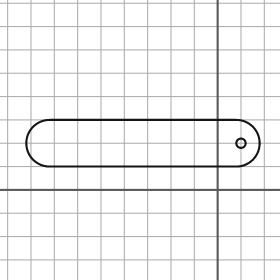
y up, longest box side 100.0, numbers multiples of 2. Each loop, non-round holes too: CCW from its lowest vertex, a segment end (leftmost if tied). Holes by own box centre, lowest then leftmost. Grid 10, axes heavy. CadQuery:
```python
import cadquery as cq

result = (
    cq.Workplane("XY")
    .moveTo(-72.0, 10.0)
    .lineTo(8.0, 10.0)
    .threePointArc((18.0, 20.0), (8.0, 30.0))
    .lineTo(-72.0, 30.0)
    .threePointArc((-82.0, 20.0), (-72.0, 10.0))
    .close()
    .moveTo(10.0, 20.0)
    .circle(2.0)
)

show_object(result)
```